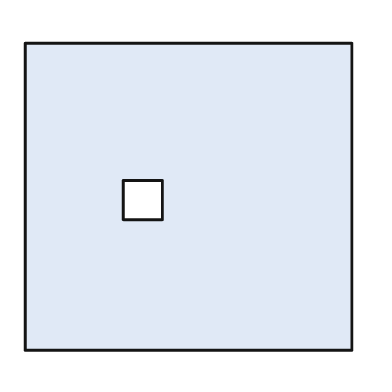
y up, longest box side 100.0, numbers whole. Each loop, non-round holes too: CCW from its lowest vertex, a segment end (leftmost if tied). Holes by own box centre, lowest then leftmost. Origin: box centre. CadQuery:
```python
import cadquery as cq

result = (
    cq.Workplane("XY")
    .moveTo(-50.0, -47.0)
    .lineTo(50.0, -47.0)
    .lineTo(50.0, 47.0)
    .lineTo(-50.0, 47.0)
    .close()
    .moveTo(-20.0, -7.0)
    .lineTo(-8.0, -7.0)
    .lineTo(-8.0, 5.0)
    .lineTo(-20.0, 5.0)
    .close()
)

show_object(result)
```